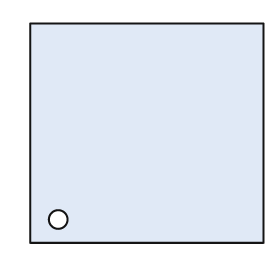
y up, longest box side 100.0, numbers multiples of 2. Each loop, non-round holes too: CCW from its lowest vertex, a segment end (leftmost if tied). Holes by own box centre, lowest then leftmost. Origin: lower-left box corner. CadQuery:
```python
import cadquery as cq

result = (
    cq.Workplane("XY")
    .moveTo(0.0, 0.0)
    .lineTo(100.0, 0.0)
    .lineTo(100.0, 94.0)
    .lineTo(0.0, 94.0)
    .close()
    .moveTo(12.0, 10.0)
    .circle(4.0)
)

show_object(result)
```